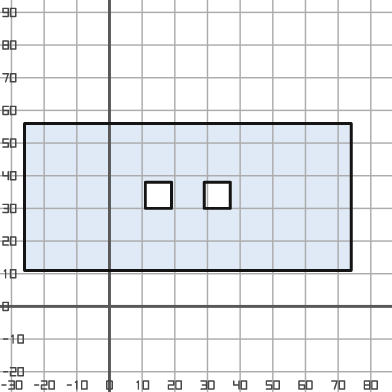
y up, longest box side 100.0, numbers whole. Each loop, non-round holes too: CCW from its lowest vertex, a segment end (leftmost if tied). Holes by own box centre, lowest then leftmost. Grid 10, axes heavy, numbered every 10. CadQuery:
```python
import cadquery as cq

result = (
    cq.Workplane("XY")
    .moveTo(-26.0, 11.0)
    .lineTo(74.0, 11.0)
    .lineTo(74.0, 56.0)
    .lineTo(-26.0, 56.0)
    .close()
    .moveTo(11.0, 30.0)
    .lineTo(19.0, 30.0)
    .lineTo(19.0, 38.0)
    .lineTo(11.0, 38.0)
    .close()
    .moveTo(29.0, 30.0)
    .lineTo(37.0, 30.0)
    .lineTo(37.0, 38.0)
    .lineTo(29.0, 38.0)
    .close()
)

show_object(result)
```